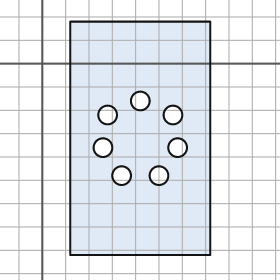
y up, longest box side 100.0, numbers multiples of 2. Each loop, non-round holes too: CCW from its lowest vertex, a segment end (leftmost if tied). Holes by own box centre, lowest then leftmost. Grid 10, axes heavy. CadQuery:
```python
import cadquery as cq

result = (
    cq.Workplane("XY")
    .moveTo(12.0, -82.0)
    .lineTo(72.0, -82.0)
    .lineTo(72.0, 18.0)
    .lineTo(12.0, 18.0)
    .close()
    .moveTo(34.0, -48.0)
    .circle(4.0)
    .moveTo(50.0, -48.0)
    .circle(4.0)
    .moveTo(26.0, -36.0)
    .circle(4.0)
    .moveTo(58.0, -36.0)
    .circle(4.0)
    .moveTo(28.0, -22.0)
    .circle(4.0)
    .moveTo(56.0, -22.0)
    .circle(4.0)
    .moveTo(42.0, -16.0)
    .circle(4.0)
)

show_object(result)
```